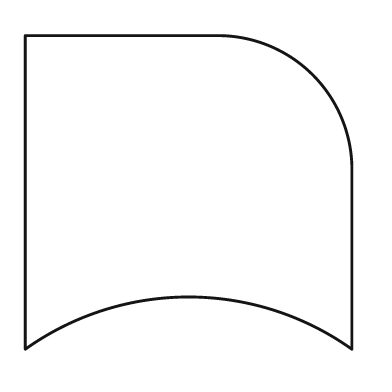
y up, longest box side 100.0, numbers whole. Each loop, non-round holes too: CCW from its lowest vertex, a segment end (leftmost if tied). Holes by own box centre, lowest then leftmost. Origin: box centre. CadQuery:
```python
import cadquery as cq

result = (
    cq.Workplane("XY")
    .moveTo(-50.0, -48.0)
    .threePointArc((0.0, -32.0), (50.0, -48.0))
    .lineTo(50.0, 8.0)
    .threePointArc((38.0, 36.0), (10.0, 48.0))
    .lineTo(-50.0, 48.0)
    .close()
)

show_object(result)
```